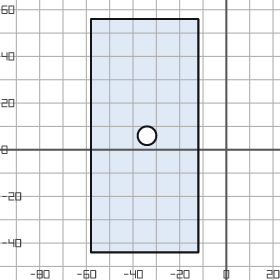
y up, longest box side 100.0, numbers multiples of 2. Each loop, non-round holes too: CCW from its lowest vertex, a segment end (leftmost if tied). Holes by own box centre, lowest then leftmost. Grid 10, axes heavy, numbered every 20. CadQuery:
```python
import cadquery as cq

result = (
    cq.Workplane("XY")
    .moveTo(-58.0, -44.0)
    .lineTo(-12.0, -44.0)
    .lineTo(-12.0, 56.0)
    .lineTo(-58.0, 56.0)
    .close()
    .moveTo(-34.0, 6.0)
    .circle(4.0)
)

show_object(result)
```